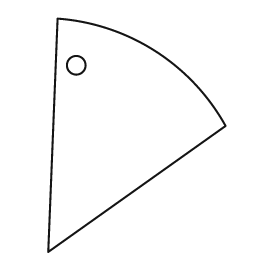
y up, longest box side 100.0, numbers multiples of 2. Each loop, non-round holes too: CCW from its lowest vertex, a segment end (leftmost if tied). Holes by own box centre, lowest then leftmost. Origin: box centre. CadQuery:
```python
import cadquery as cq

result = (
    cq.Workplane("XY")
    .moveTo(-38.0, -50.0)
    .lineTo(38.0, 4.0)
    .threePointArc((8.0, 36.0), (-34.0, 50.0))
    .close()
    .moveTo(-26.0, 30.0)
    .circle(4.0)
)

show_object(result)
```